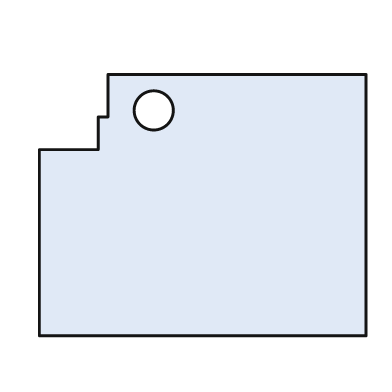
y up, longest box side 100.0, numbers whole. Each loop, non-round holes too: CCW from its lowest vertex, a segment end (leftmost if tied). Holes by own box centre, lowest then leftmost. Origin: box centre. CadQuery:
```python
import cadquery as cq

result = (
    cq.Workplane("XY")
    .moveTo(-50.0, -40.0)
    .lineTo(50.0, -40.0)
    .lineTo(50.0, 40.0)
    .lineTo(-29.0, 40.0)
    .lineTo(-29.0, 27.0)
    .lineTo(-32.0, 27.0)
    .lineTo(-32.0, 17.0)
    .lineTo(-50.0, 17.0)
    .close()
    .moveTo(-15.0, 29.0)
    .circle(6.0)
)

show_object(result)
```